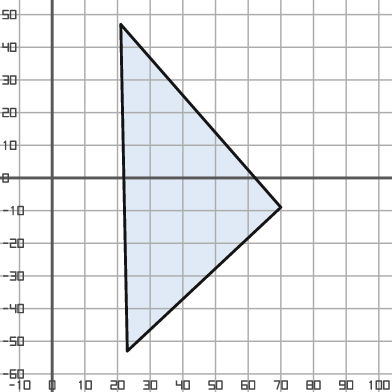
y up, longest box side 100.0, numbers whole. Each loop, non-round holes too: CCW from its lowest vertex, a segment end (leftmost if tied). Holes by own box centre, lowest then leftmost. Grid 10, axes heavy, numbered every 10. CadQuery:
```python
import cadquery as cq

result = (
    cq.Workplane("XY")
    .moveTo(23.0, -53.0)
    .lineTo(70.0, -9.0)
    .lineTo(21.0, 47.0)
    .close()
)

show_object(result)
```